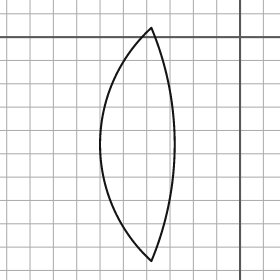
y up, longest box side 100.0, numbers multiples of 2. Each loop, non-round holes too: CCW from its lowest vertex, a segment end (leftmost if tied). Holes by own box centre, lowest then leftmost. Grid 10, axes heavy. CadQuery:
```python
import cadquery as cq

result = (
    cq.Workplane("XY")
    .moveTo(-38.0, -96.0)
    .threePointArc((-28.0, -46.0), (-38.0, 4.0))
    .threePointArc((-60.0, -46.0), (-38.0, -96.0))
    .close()
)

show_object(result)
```